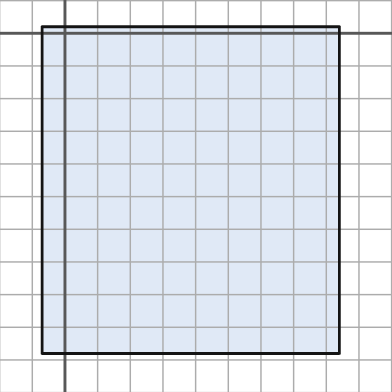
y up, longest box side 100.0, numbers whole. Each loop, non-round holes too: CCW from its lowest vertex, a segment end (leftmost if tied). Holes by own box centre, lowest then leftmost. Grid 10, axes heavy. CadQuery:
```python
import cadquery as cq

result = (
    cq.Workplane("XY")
    .moveTo(-7.0, -98.0)
    .lineTo(84.0, -98.0)
    .lineTo(84.0, 2.0)
    .lineTo(-7.0, 2.0)
    .close()
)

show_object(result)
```